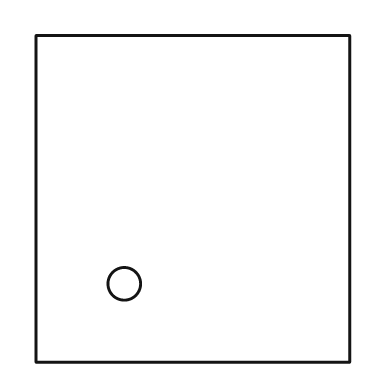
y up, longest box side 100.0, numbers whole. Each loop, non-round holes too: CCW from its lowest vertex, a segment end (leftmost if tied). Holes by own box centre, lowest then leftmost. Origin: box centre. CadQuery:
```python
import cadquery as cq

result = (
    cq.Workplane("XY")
    .moveTo(-48.0, -50.0)
    .lineTo(48.0, -50.0)
    .lineTo(48.0, 50.0)
    .lineTo(-48.0, 50.0)
    .close()
    .moveTo(-21.0, -26.0)
    .circle(5.0)
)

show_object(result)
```